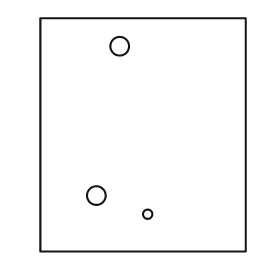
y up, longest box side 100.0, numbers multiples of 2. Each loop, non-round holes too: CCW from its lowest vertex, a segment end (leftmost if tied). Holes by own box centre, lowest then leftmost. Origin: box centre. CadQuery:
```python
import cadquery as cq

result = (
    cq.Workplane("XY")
    .moveTo(-44.0, -50.0)
    .lineTo(44.0, -50.0)
    .lineTo(44.0, 50.0)
    .lineTo(-44.0, 50.0)
    .close()
    .moveTo(2.0, -34.0)
    .circle(2.0)
    .moveTo(-20.0, -26.0)
    .circle(4.0)
    .moveTo(-10.0, 38.0)
    .circle(4.0)
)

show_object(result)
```